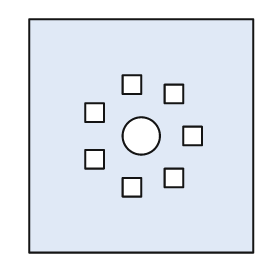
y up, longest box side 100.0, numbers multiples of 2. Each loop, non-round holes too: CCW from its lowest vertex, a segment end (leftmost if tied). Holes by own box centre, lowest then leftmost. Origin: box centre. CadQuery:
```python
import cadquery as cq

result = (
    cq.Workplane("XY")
    .moveTo(-48.0, -50.0)
    .lineTo(48.0, -50.0)
    .lineTo(48.0, 50.0)
    .lineTo(-48.0, 50.0)
    .close()
    .moveTo(-8.0, -26.0)
    .lineTo(0.0, -26.0)
    .lineTo(0.0, -18.0)
    .lineTo(-8.0, -18.0)
    .close()
    .moveTo(10.0, -22.0)
    .lineTo(18.0, -22.0)
    .lineTo(18.0, -14.0)
    .lineTo(10.0, -14.0)
    .close()
    .moveTo(-24.0, -14.0)
    .lineTo(-16.0, -14.0)
    .lineTo(-16.0, -6.0)
    .lineTo(-24.0, -6.0)
    .close()
    .moveTo(0.0, 0.0)
    .circle(8.0)
    .moveTo(18.0, -4.0)
    .lineTo(26.0, -4.0)
    .lineTo(26.0, 4.0)
    .lineTo(18.0, 4.0)
    .close()
    .moveTo(-24.0, 6.0)
    .lineTo(-16.0, 6.0)
    .lineTo(-16.0, 14.0)
    .lineTo(-24.0, 14.0)
    .close()
    .moveTo(10.0, 14.0)
    .lineTo(18.0, 14.0)
    .lineTo(18.0, 22.0)
    .lineTo(10.0, 22.0)
    .close()
    .moveTo(-8.0, 18.0)
    .lineTo(0.0, 18.0)
    .lineTo(0.0, 26.0)
    .lineTo(-8.0, 26.0)
    .close()
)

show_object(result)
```